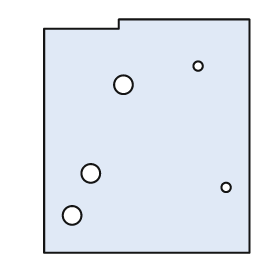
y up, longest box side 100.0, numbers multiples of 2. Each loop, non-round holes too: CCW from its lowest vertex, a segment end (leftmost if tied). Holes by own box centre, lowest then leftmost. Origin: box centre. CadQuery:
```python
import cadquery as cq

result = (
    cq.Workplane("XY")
    .moveTo(-44.0, -50.0)
    .lineTo(44.0, -50.0)
    .lineTo(44.0, 50.0)
    .lineTo(-12.0, 50.0)
    .lineTo(-12.0, 46.0)
    .lineTo(-44.0, 46.0)
    .close()
    .moveTo(-32.0, -34.0)
    .circle(4.0)
    .moveTo(34.0, -22.0)
    .circle(2.0)
    .moveTo(-24.0, -16.0)
    .circle(4.0)
    .moveTo(-10.0, 22.0)
    .circle(4.0)
    .moveTo(22.0, 30.0)
    .circle(2.0)
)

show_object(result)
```